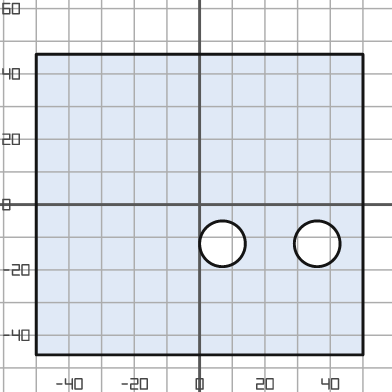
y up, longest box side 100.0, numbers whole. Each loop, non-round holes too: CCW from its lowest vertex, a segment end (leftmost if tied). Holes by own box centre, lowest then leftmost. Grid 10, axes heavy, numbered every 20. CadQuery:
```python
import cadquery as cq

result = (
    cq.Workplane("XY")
    .moveTo(-50.0, -46.0)
    .lineTo(50.0, -46.0)
    .lineTo(50.0, 46.0)
    .lineTo(-50.0, 46.0)
    .close()
    .moveTo(7.0, -12.0)
    .circle(7.0)
    .moveTo(36.0, -12.0)
    .circle(7.0)
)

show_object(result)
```